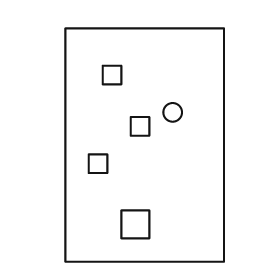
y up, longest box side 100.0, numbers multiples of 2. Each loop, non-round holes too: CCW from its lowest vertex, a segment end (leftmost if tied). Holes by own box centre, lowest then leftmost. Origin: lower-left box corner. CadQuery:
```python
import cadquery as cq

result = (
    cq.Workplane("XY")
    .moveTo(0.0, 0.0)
    .lineTo(68.0, 0.0)
    .lineTo(68.0, 100.0)
    .lineTo(0.0, 100.0)
    .close()
    .moveTo(24.0, 10.0)
    .lineTo(36.0, 10.0)
    .lineTo(36.0, 22.0)
    .lineTo(24.0, 22.0)
    .close()
    .moveTo(10.0, 38.0)
    .lineTo(18.0, 38.0)
    .lineTo(18.0, 46.0)
    .lineTo(10.0, 46.0)
    .close()
    .moveTo(28.0, 54.0)
    .lineTo(36.0, 54.0)
    .lineTo(36.0, 62.0)
    .lineTo(28.0, 62.0)
    .close()
    .moveTo(46.0, 64.0)
    .circle(4.0)
    .moveTo(16.0, 76.0)
    .lineTo(24.0, 76.0)
    .lineTo(24.0, 84.0)
    .lineTo(16.0, 84.0)
    .close()
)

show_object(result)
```